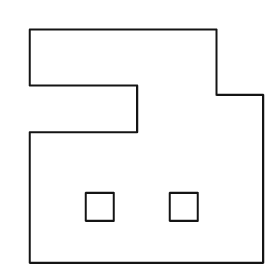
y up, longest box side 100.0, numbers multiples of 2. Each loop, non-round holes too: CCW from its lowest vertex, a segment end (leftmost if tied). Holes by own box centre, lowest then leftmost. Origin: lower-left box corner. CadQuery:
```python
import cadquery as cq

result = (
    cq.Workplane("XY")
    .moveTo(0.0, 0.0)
    .lineTo(100.0, 0.0)
    .lineTo(100.0, 72.0)
    .lineTo(80.0, 72.0)
    .lineTo(80.0, 100.0)
    .lineTo(0.0, 100.0)
    .lineTo(0.0, 76.0)
    .lineTo(46.0, 76.0)
    .lineTo(46.0, 56.0)
    .lineTo(0.0, 56.0)
    .close()
    .moveTo(24.0, 18.0)
    .lineTo(36.0, 18.0)
    .lineTo(36.0, 30.0)
    .lineTo(24.0, 30.0)
    .close()
    .moveTo(60.0, 18.0)
    .lineTo(72.0, 18.0)
    .lineTo(72.0, 30.0)
    .lineTo(60.0, 30.0)
    .close()
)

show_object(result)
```